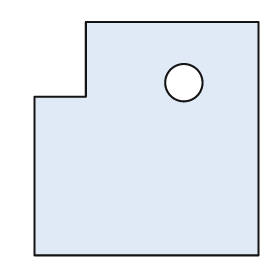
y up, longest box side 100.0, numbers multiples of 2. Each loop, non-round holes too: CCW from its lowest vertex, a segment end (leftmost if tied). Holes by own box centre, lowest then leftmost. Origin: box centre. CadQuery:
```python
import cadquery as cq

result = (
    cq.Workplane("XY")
    .moveTo(-48.0, -50.0)
    .lineTo(48.0, -50.0)
    .lineTo(48.0, 50.0)
    .lineTo(-26.0, 50.0)
    .lineTo(-26.0, 18.0)
    .lineTo(-48.0, 18.0)
    .close()
    .moveTo(16.0, 24.0)
    .circle(8.0)
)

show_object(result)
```